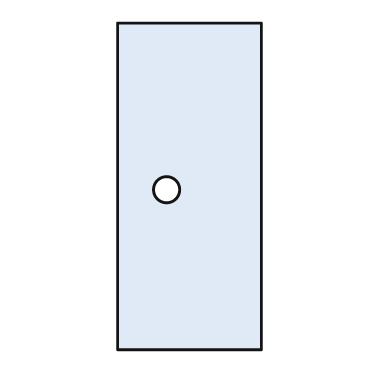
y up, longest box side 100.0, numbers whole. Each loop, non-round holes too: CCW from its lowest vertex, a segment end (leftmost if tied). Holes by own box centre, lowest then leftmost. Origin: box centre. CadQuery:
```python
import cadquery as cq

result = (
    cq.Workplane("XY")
    .moveTo(-22.0, -50.0)
    .lineTo(22.0, -50.0)
    .lineTo(22.0, 50.0)
    .lineTo(-22.0, 50.0)
    .close()
    .moveTo(-7.0, -1.0)
    .circle(4.0)
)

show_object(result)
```